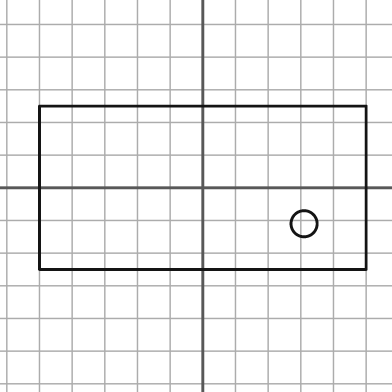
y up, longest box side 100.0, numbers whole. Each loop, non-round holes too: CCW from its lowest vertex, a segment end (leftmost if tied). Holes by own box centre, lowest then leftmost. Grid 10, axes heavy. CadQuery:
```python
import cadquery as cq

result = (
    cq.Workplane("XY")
    .moveTo(-50.0, -25.0)
    .lineTo(50.0, -25.0)
    .lineTo(50.0, 25.0)
    .lineTo(-50.0, 25.0)
    .close()
    .moveTo(31.0, -11.0)
    .circle(4.0)
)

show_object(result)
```